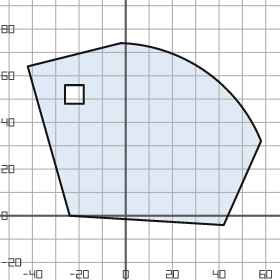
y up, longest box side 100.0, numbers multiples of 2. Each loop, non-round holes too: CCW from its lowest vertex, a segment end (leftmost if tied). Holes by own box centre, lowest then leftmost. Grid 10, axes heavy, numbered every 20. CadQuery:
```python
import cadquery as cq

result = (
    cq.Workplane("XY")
    .moveTo(42.0, -4.0)
    .lineTo(58.0, 32.0)
    .threePointArc((34.0, 62.0), (-2.0, 74.0))
    .lineTo(-42.0, 64.0)
    .lineTo(-24.0, 0.0)
    .close()
    .moveTo(-26.0, 48.0)
    .lineTo(-18.0, 48.0)
    .lineTo(-18.0, 56.0)
    .lineTo(-26.0, 56.0)
    .close()
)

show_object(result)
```